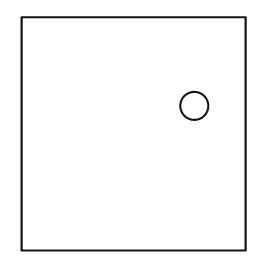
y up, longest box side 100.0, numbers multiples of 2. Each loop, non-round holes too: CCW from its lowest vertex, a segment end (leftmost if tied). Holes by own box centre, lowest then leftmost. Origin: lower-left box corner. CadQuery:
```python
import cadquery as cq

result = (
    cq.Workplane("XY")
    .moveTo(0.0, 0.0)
    .lineTo(96.0, 0.0)
    .lineTo(96.0, 100.0)
    .lineTo(0.0, 100.0)
    .close()
    .moveTo(74.0, 62.0)
    .circle(6.0)
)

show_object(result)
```